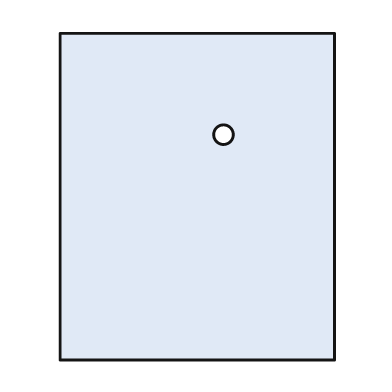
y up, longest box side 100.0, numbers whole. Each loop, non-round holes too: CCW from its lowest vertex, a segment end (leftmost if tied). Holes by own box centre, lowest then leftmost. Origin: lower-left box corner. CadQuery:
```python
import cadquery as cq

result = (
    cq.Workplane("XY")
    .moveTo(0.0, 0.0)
    .lineTo(84.0, 0.0)
    .lineTo(84.0, 100.0)
    .lineTo(0.0, 100.0)
    .close()
    .moveTo(50.0, 69.0)
    .circle(3.0)
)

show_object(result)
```